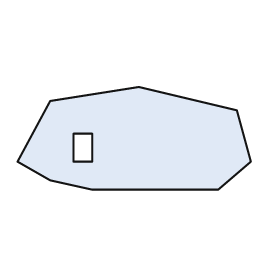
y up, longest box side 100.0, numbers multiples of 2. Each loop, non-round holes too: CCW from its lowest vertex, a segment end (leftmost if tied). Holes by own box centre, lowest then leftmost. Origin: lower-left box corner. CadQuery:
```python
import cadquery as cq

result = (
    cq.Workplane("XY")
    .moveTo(32.0, 0.0)
    .lineTo(86.0, 0.0)
    .lineTo(100.0, 12.0)
    .lineTo(94.0, 34.0)
    .lineTo(52.0, 44.0)
    .lineTo(14.0, 38.0)
    .lineTo(0.0, 12.0)
    .lineTo(14.0, 4.0)
    .close()
    .moveTo(24.0, 12.0)
    .lineTo(32.0, 12.0)
    .lineTo(32.0, 24.0)
    .lineTo(24.0, 24.0)
    .close()
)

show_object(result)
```